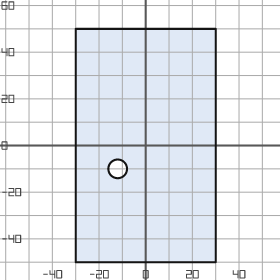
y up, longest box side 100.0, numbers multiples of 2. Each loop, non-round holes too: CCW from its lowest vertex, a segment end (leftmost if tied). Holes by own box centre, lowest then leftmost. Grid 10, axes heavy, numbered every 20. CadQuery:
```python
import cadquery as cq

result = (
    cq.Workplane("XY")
    .moveTo(-30.0, -50.0)
    .lineTo(30.0, -50.0)
    .lineTo(30.0, 50.0)
    .lineTo(-30.0, 50.0)
    .close()
    .moveTo(-12.0, -10.0)
    .circle(4.0)
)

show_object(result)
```